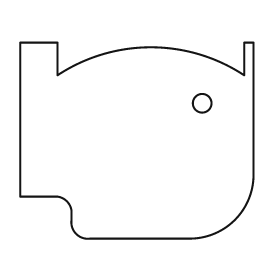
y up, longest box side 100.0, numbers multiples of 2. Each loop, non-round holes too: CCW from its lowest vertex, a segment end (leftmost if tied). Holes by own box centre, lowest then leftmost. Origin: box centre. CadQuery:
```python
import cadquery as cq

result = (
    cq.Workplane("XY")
    .moveTo(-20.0, -42.0)
    .lineTo(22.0, -42.0)
    .threePointArc((42.0, -34.0), (50.0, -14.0))
    .lineTo(50.0, 42.0)
    .lineTo(46.0, 42.0)
    .lineTo(46.0, 28.0)
    .threePointArc((6.0, 40.0), (-34.0, 28.0))
    .lineTo(-34.0, 42.0)
    .lineTo(-50.0, 42.0)
    .lineTo(-50.0, -24.0)
    .lineTo(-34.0, -24.0)
    .threePointArc((-30.0, -26.0), (-28.0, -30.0))
    .lineTo(-28.0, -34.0)
    .threePointArc((-26.0, -40.0), (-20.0, -42.0))
    .close()
    .moveTo(28.0, 16.0)
    .circle(4.0)
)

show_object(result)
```